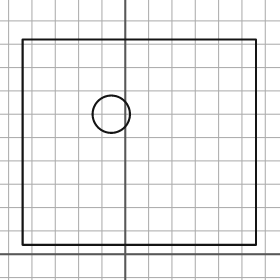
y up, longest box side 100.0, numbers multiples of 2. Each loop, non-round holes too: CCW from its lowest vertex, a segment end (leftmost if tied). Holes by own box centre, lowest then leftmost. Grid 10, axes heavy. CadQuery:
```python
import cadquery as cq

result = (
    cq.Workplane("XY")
    .moveTo(-44.0, 4.0)
    .lineTo(56.0, 4.0)
    .lineTo(56.0, 92.0)
    .lineTo(-44.0, 92.0)
    .close()
    .moveTo(-6.0, 60.0)
    .circle(8.0)
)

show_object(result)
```